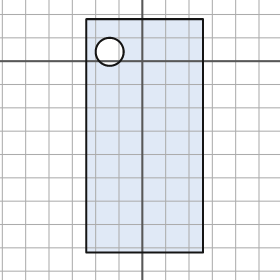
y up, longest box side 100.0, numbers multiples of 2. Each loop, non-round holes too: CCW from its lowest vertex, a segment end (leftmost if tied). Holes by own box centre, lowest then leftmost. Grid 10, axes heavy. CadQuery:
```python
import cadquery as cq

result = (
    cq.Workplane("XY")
    .moveTo(-24.0, -82.0)
    .lineTo(26.0, -82.0)
    .lineTo(26.0, 18.0)
    .lineTo(-24.0, 18.0)
    .close()
    .moveTo(-14.0, 4.0)
    .circle(6.0)
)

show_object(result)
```